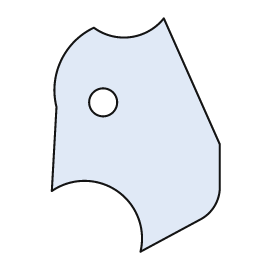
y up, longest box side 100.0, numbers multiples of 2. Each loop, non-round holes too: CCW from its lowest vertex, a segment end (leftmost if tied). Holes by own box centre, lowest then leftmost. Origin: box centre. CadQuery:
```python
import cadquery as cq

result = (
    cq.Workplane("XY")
    .moveTo(2.0, -50.0)
    .lineTo(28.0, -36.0)
    .threePointArc((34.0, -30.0), (36.0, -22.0))
    .lineTo(36.0, -4.0)
    .lineTo(12.0, 50.0)
    .threePointArc((-2.0, 42.0), (-18.0, 46.0))
    .threePointArc((-32.0, 32.0), (-34.0, 12.0))
    .lineTo(-36.0, -24.0)
    .threePointArc((-8.0, -24.0), (2.0, -50.0))
    .close()
    .moveTo(-14.0, 14.0)
    .circle(6.0)
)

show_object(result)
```